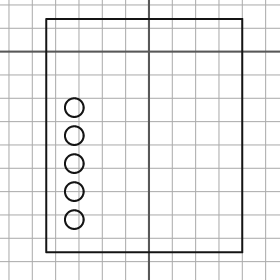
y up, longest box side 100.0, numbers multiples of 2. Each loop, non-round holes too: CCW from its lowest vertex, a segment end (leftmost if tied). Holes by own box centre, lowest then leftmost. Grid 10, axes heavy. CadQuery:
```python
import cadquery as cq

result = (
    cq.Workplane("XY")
    .moveTo(-44.0, -86.0)
    .lineTo(40.0, -86.0)
    .lineTo(40.0, 14.0)
    .lineTo(-44.0, 14.0)
    .close()
    .moveTo(-32.0, -72.0)
    .circle(4.0)
    .moveTo(-32.0, -60.0)
    .circle(4.0)
    .moveTo(-32.0, -48.0)
    .circle(4.0)
    .moveTo(-32.0, -36.0)
    .circle(4.0)
    .moveTo(-32.0, -24.0)
    .circle(4.0)
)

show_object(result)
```